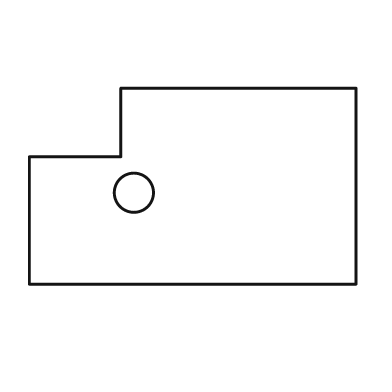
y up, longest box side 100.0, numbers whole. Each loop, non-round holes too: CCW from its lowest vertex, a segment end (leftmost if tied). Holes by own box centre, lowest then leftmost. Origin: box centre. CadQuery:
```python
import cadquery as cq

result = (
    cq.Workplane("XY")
    .moveTo(-50.0, -30.0)
    .lineTo(50.0, -30.0)
    .lineTo(50.0, 30.0)
    .lineTo(-22.0, 30.0)
    .lineTo(-22.0, 9.0)
    .lineTo(-50.0, 9.0)
    .close()
    .moveTo(-18.0, -2.0)
    .circle(6.0)
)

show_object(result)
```